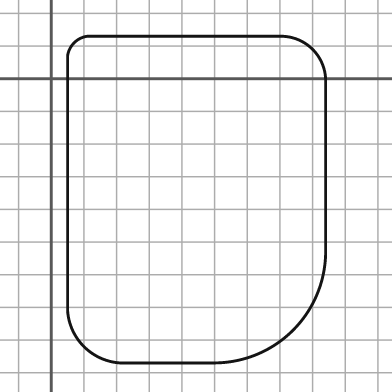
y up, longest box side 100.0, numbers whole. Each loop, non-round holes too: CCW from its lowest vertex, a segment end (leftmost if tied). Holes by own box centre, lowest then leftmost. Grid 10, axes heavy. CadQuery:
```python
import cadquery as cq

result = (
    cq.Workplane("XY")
    .moveTo(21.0, -87.0)
    .lineTo(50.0, -87.0)
    .threePointArc((74.0, -77.0), (84.0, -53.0))
    .lineTo(84.0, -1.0)
    .threePointArc((80.0, 9.0), (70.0, 13.0))
    .lineTo(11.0, 13.0)
    .threePointArc((7.0, 11.0), (5.0, 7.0))
    .lineTo(5.0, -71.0)
    .threePointArc((10.0, -82.0), (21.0, -87.0))
    .close()
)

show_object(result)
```